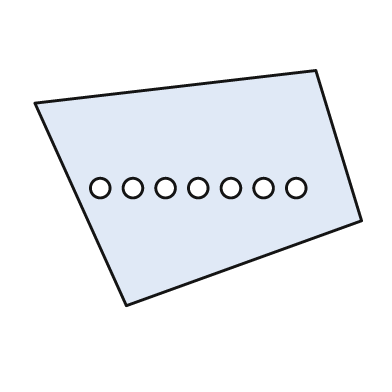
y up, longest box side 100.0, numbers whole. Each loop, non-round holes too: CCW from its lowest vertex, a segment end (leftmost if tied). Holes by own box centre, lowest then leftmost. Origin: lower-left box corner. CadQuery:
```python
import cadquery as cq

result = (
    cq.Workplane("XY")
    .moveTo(28.0, 0.0)
    .lineTo(100.0, 26.0)
    .lineTo(86.0, 72.0)
    .lineTo(0.0, 62.0)
    .close()
    .moveTo(20.0, 36.0)
    .circle(3.0)
    .moveTo(30.0, 36.0)
    .circle(3.0)
    .moveTo(40.0, 36.0)
    .circle(3.0)
    .moveTo(50.0, 36.0)
    .circle(3.0)
    .moveTo(60.0, 36.0)
    .circle(3.0)
    .moveTo(70.0, 36.0)
    .circle(3.0)
    .moveTo(80.0, 36.0)
    .circle(3.0)
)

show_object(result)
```